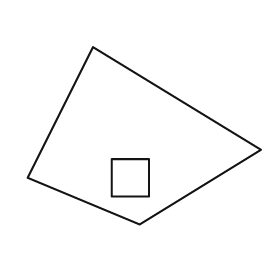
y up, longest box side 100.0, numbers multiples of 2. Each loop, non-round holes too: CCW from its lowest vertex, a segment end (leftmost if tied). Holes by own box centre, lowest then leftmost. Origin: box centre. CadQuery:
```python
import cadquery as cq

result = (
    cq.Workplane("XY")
    .moveTo(-2.0, -38.0)
    .lineTo(50.0, -6.0)
    .lineTo(-22.0, 38.0)
    .lineTo(-50.0, -18.0)
    .close()
    .moveTo(-14.0, -26.0)
    .lineTo(2.0, -26.0)
    .lineTo(2.0, -10.0)
    .lineTo(-14.0, -10.0)
    .close()
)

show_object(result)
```